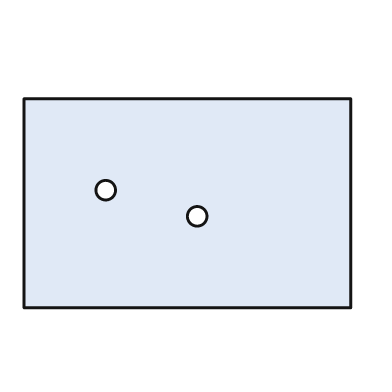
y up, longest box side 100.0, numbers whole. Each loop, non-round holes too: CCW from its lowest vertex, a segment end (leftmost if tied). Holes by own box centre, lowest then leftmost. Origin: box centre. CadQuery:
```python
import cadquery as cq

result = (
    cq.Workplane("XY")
    .moveTo(-50.0, -32.0)
    .lineTo(50.0, -32.0)
    .lineTo(50.0, 32.0)
    .lineTo(-50.0, 32.0)
    .close()
    .moveTo(3.0, -4.0)
    .circle(3.0)
    .moveTo(-25.0, 4.0)
    .circle(3.0)
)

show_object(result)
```